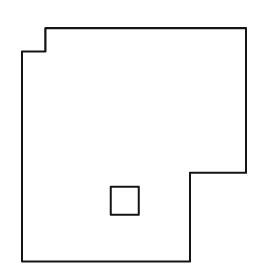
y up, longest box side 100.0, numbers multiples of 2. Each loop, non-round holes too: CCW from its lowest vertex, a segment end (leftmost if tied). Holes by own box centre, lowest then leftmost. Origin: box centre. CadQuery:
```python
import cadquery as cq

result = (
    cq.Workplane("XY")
    .moveTo(-48.0, -50.0)
    .lineTo(24.0, -50.0)
    .lineTo(24.0, -12.0)
    .lineTo(48.0, -12.0)
    .lineTo(48.0, 50.0)
    .lineTo(-38.0, 50.0)
    .lineTo(-38.0, 40.0)
    .lineTo(-48.0, 40.0)
    .close()
    .moveTo(-10.0, -30.0)
    .lineTo(2.0, -30.0)
    .lineTo(2.0, -18.0)
    .lineTo(-10.0, -18.0)
    .close()
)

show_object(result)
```